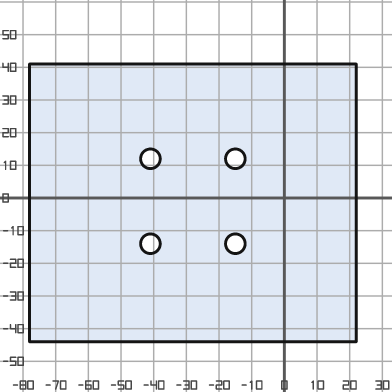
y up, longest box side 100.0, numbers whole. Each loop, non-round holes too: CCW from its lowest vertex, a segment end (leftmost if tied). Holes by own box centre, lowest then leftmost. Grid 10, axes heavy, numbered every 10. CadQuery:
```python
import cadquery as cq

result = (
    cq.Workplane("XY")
    .moveTo(-78.0, -44.0)
    .lineTo(22.0, -44.0)
    .lineTo(22.0, 41.0)
    .lineTo(-78.0, 41.0)
    .close()
    .moveTo(-41.0, -14.0)
    .circle(3.0)
    .moveTo(-15.0, -14.0)
    .circle(3.0)
    .moveTo(-41.0, 12.0)
    .circle(3.0)
    .moveTo(-15.0, 12.0)
    .circle(3.0)
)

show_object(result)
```